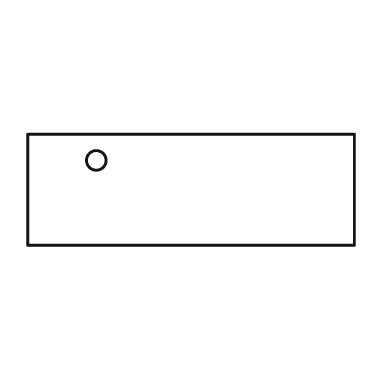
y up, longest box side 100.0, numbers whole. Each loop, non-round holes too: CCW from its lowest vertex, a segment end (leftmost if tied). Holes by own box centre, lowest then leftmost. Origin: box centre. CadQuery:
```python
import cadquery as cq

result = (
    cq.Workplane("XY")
    .moveTo(-50.0, -17.0)
    .lineTo(50.0, -17.0)
    .lineTo(50.0, 17.0)
    .lineTo(-50.0, 17.0)
    .close()
    .moveTo(-29.0, 9.0)
    .circle(3.0)
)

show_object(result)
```